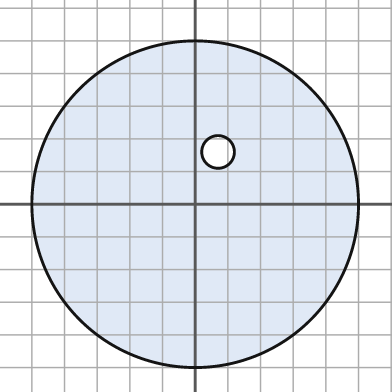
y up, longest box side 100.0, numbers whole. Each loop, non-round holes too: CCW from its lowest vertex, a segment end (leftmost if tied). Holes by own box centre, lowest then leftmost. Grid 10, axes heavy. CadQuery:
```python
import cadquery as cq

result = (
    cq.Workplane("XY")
    .moveTo(0.0, 0.0)
    .circle(50.0)
    .moveTo(7.0, 16.0)
    .circle(5.0)
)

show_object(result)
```